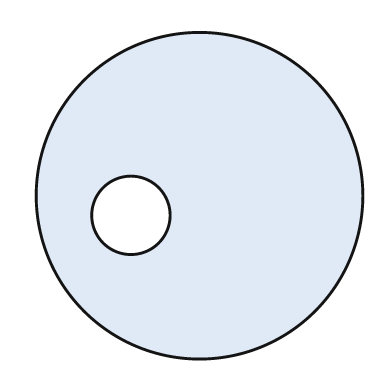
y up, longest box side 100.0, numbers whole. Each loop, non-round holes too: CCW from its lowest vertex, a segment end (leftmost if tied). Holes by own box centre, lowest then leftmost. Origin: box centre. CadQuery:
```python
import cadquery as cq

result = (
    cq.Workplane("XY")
    .moveTo(0.0, 0.0)
    .circle(50.0)
    .moveTo(-21.0, -6.0)
    .circle(12.0)
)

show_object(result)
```